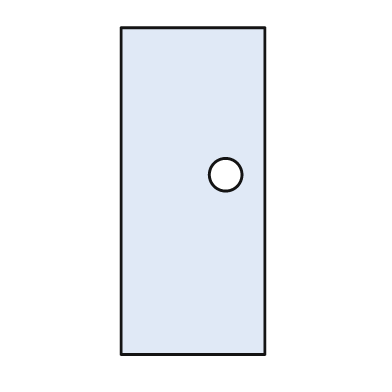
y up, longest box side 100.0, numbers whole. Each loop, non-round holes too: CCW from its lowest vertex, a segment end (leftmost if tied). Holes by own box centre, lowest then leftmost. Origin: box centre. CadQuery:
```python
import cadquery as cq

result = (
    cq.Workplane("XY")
    .moveTo(-22.0, -50.0)
    .lineTo(22.0, -50.0)
    .lineTo(22.0, 50.0)
    .lineTo(-22.0, 50.0)
    .close()
    .moveTo(10.0, 5.0)
    .circle(5.0)
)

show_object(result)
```